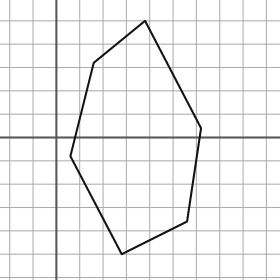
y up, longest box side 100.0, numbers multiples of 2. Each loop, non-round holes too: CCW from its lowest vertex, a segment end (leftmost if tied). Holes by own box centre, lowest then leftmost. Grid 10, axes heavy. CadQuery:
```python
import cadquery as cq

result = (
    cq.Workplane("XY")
    .moveTo(28.0, -50.0)
    .lineTo(56.0, -36.0)
    .lineTo(62.0, 4.0)
    .lineTo(38.0, 50.0)
    .lineTo(16.0, 32.0)
    .lineTo(6.0, -8.0)
    .close()
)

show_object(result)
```